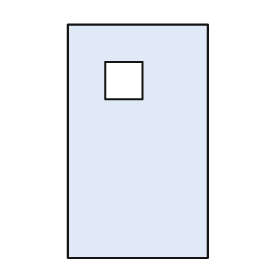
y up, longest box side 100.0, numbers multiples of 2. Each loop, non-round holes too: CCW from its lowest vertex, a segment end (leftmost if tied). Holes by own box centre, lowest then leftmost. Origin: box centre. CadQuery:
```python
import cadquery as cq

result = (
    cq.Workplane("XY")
    .moveTo(-30.0, -50.0)
    .lineTo(30.0, -50.0)
    .lineTo(30.0, 50.0)
    .lineTo(-30.0, 50.0)
    .close()
    .moveTo(-14.0, 18.0)
    .lineTo(2.0, 18.0)
    .lineTo(2.0, 34.0)
    .lineTo(-14.0, 34.0)
    .close()
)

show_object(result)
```